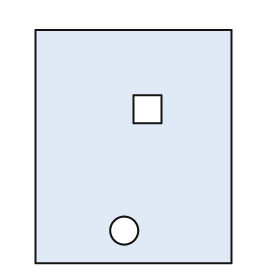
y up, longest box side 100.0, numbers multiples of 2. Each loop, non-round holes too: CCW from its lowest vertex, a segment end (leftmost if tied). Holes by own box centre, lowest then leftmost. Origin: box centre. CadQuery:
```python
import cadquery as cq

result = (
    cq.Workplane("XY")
    .moveTo(-42.0, -50.0)
    .lineTo(42.0, -50.0)
    .lineTo(42.0, 50.0)
    .lineTo(-42.0, 50.0)
    .close()
    .moveTo(-4.0, -36.0)
    .circle(6.0)
    .moveTo(0.0, 10.0)
    .lineTo(12.0, 10.0)
    .lineTo(12.0, 22.0)
    .lineTo(0.0, 22.0)
    .close()
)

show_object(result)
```